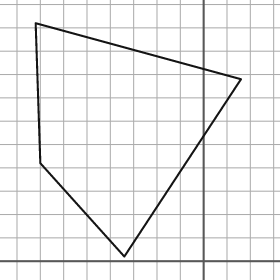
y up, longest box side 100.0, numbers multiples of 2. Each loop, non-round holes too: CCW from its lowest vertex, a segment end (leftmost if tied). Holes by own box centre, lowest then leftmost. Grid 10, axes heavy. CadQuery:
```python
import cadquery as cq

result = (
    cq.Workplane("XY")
    .moveTo(-34.0, 2.0)
    .lineTo(16.0, 78.0)
    .lineTo(-72.0, 102.0)
    .lineTo(-70.0, 42.0)
    .close()
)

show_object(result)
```